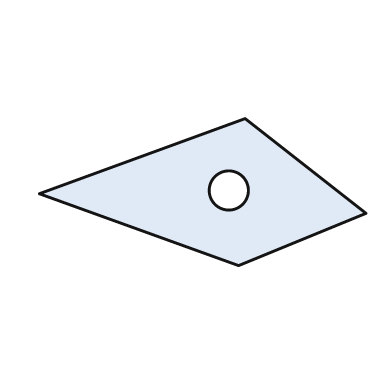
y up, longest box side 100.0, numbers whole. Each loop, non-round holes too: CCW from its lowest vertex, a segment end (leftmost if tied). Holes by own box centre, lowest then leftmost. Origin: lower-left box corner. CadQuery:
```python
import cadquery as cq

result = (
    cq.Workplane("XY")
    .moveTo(61.0, 0.0)
    .lineTo(100.0, 16.0)
    .lineTo(63.0, 45.0)
    .lineTo(0.0, 22.0)
    .close()
    .moveTo(58.0, 23.0)
    .circle(6.0)
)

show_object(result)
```